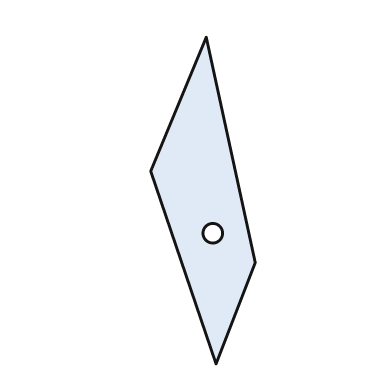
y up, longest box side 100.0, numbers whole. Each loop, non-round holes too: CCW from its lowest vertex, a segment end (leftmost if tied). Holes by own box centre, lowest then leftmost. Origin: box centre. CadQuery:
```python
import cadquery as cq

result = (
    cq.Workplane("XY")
    .moveTo(4.0, -50.0)
    .lineTo(16.0, -19.0)
    .lineTo(1.0, 50.0)
    .lineTo(-16.0, 9.0)
    .close()
    .moveTo(3.0, -10.0)
    .circle(3.0)
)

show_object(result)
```